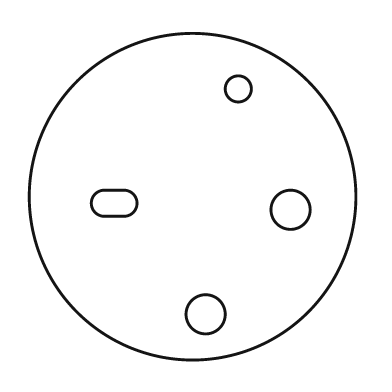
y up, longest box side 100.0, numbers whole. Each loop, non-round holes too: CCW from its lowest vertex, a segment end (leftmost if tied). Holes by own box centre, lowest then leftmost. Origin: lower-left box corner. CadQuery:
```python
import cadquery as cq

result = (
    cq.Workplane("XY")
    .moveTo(50.0, 50.0)
    .circle(50.0)
    .moveTo(54.0, 14.0)
    .circle(6.0)
    .moveTo(80.0, 46.0)
    .circle(6.0)
    .moveTo(23.0, 44.0)
    .lineTo(29.0, 44.0)
    .threePointArc((33.0, 48.0), (29.0, 52.0))
    .lineTo(23.0, 52.0)
    .threePointArc((19.0, 48.0), (23.0, 44.0))
    .close()
    .moveTo(64.0, 83.0)
    .circle(4.0)
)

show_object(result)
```